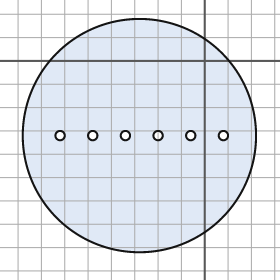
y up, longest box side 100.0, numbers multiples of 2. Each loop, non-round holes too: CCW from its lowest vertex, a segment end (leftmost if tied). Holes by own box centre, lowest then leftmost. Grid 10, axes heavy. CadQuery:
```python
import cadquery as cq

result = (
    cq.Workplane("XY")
    .moveTo(-28.0, -32.0)
    .circle(50.0)
    .moveTo(-62.0, -32.0)
    .circle(2.0)
    .moveTo(-48.0, -32.0)
    .circle(2.0)
    .moveTo(-34.0, -32.0)
    .circle(2.0)
    .moveTo(-20.0, -32.0)
    .circle(2.0)
    .moveTo(-6.0, -32.0)
    .circle(2.0)
    .moveTo(8.0, -32.0)
    .circle(2.0)
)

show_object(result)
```